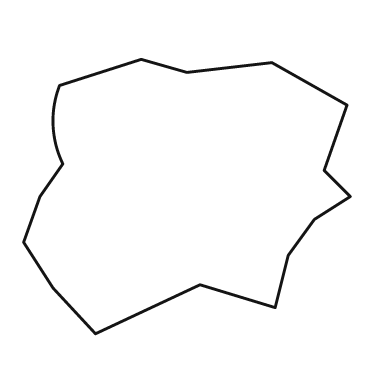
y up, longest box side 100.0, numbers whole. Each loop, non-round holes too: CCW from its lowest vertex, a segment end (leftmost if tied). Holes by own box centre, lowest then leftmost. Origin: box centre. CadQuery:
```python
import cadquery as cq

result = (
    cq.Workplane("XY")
    .moveTo(-28.0, -42.0)
    .lineTo(4.0, -27.0)
    .lineTo(27.0, -34.0)
    .lineTo(31.0, -18.0)
    .lineTo(39.0, -7.0)
    .lineTo(50.0, 0.0)
    .lineTo(42.0, 8.0)
    .lineTo(49.0, 28.0)
    .lineTo(26.0, 41.0)
    .lineTo(0.0, 38.0)
    .lineTo(-14.0, 42.0)
    .lineTo(-39.0, 34.0)
    .threePointArc((-41.0, 22.0), (-38.0, 10.0))
    .lineTo(-45.0, 0.0)
    .lineTo(-50.0, -14.0)
    .lineTo(-41.0, -28.0)
    .close()
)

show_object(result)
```